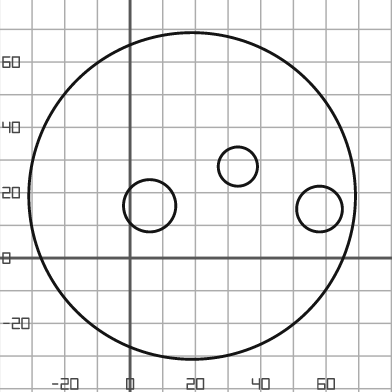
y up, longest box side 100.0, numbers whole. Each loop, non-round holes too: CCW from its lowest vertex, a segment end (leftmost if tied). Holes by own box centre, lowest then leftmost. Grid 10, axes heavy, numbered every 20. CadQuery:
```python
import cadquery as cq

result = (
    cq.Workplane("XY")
    .moveTo(19.0, 19.0)
    .circle(50.0)
    .moveTo(58.0, 15.0)
    .circle(7.0)
    .moveTo(6.0, 16.0)
    .circle(8.0)
    .moveTo(33.0, 28.0)
    .circle(6.0)
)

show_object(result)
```